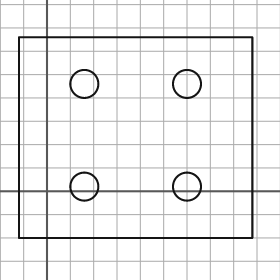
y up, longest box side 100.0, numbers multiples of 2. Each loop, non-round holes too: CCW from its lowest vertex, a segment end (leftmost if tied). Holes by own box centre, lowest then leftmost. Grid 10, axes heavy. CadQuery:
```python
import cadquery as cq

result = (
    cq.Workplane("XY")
    .moveTo(-12.0, -20.0)
    .lineTo(88.0, -20.0)
    .lineTo(88.0, 66.0)
    .lineTo(-12.0, 66.0)
    .close()
    .moveTo(16.0, 2.0)
    .circle(6.0)
    .moveTo(60.0, 2.0)
    .circle(6.0)
    .moveTo(16.0, 46.0)
    .circle(6.0)
    .moveTo(60.0, 46.0)
    .circle(6.0)
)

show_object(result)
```